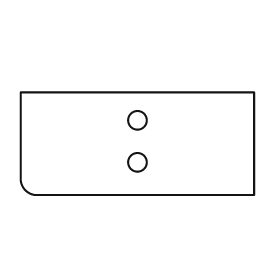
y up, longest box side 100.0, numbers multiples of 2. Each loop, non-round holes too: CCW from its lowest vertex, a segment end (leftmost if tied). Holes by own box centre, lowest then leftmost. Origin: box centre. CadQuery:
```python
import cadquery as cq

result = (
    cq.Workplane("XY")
    .moveTo(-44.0, -22.0)
    .lineTo(50.0, -22.0)
    .lineTo(50.0, 22.0)
    .lineTo(-50.0, 22.0)
    .lineTo(-50.0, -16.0)
    .threePointArc((-48.0, -20.0), (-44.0, -22.0))
    .close()
    .moveTo(0.0, -8.0)
    .circle(4.0)
    .moveTo(0.0, 10.0)
    .circle(4.0)
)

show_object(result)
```